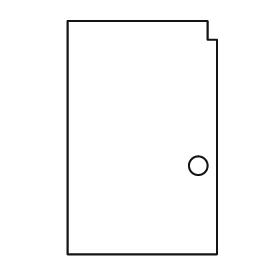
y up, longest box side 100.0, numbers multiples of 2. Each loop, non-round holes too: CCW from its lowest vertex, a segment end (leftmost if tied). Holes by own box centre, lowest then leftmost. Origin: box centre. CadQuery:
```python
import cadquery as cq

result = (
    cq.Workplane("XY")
    .moveTo(-32.0, -50.0)
    .lineTo(32.0, -50.0)
    .lineTo(32.0, 42.0)
    .lineTo(28.0, 42.0)
    .lineTo(28.0, 50.0)
    .lineTo(-32.0, 50.0)
    .close()
    .moveTo(24.0, -12.0)
    .circle(4.0)
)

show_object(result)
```